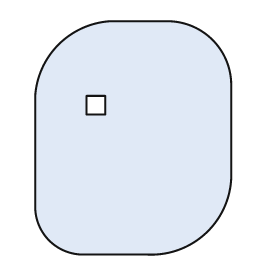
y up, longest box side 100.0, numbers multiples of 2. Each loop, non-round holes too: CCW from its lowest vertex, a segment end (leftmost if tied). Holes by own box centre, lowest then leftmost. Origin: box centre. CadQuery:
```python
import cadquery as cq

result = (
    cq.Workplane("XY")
    .moveTo(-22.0, -50.0)
    .lineTo(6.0, -50.0)
    .threePointArc((32.0, -40.0), (42.0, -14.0))
    .lineTo(42.0, 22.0)
    .threePointArc((34.0, 42.0), (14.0, 50.0))
    .lineTo(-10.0, 50.0)
    .threePointArc((-32.0, 40.0), (-42.0, 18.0))
    .lineTo(-42.0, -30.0)
    .threePointArc((-36.0, -44.0), (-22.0, -50.0))
    .close()
    .moveTo(-20.0, 10.0)
    .lineTo(-12.0, 10.0)
    .lineTo(-12.0, 18.0)
    .lineTo(-20.0, 18.0)
    .close()
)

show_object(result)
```